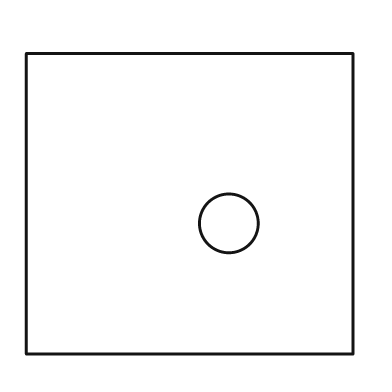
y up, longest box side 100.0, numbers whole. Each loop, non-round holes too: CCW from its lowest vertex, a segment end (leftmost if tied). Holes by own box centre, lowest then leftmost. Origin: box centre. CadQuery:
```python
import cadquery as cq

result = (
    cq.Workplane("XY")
    .moveTo(-50.0, -46.0)
    .lineTo(50.0, -46.0)
    .lineTo(50.0, 46.0)
    .lineTo(-50.0, 46.0)
    .close()
    .moveTo(12.0, -6.0)
    .circle(9.0)
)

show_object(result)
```